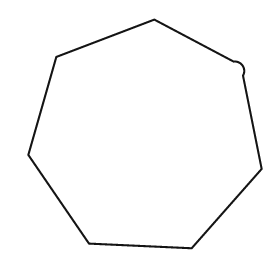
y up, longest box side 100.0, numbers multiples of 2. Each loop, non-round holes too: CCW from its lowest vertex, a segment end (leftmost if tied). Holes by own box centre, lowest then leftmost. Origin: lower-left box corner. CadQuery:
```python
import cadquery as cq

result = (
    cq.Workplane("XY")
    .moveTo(70.0, 0.0)
    .lineTo(100.0, 34.0)
    .lineTo(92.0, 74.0)
    .threePointArc((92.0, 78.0), (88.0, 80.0))
    .lineTo(54.0, 98.0)
    .lineTo(12.0, 82.0)
    .lineTo(0.0, 40.0)
    .lineTo(26.0, 2.0)
    .close()
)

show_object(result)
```